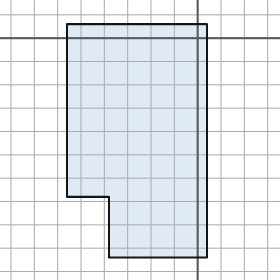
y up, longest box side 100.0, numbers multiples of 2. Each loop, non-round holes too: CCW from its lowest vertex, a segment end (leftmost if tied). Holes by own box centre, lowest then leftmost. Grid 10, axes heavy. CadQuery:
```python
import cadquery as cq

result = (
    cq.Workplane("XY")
    .moveTo(-38.0, -94.0)
    .lineTo(4.0, -94.0)
    .lineTo(4.0, 6.0)
    .lineTo(-56.0, 6.0)
    .lineTo(-56.0, -68.0)
    .lineTo(-38.0, -68.0)
    .close()
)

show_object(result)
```